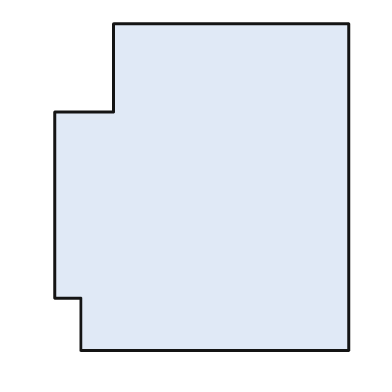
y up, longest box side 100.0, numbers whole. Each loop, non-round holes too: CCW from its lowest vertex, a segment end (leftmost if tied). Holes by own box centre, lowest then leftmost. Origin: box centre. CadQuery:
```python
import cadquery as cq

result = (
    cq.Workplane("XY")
    .moveTo(-37.0, -50.0)
    .lineTo(45.0, -50.0)
    .lineTo(45.0, 50.0)
    .lineTo(-27.0, 50.0)
    .lineTo(-27.0, 23.0)
    .lineTo(-45.0, 23.0)
    .lineTo(-45.0, -34.0)
    .lineTo(-37.0, -34.0)
    .close()
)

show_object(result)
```